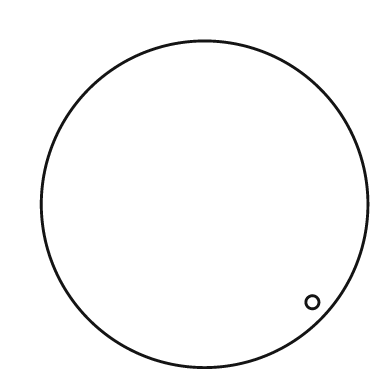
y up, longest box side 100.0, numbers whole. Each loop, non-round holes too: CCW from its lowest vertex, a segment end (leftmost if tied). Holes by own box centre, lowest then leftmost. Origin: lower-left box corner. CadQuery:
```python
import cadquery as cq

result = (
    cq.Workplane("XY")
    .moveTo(50.0, 50.0)
    .circle(50.0)
    .moveTo(83.0, 20.0)
    .circle(2.0)
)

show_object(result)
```